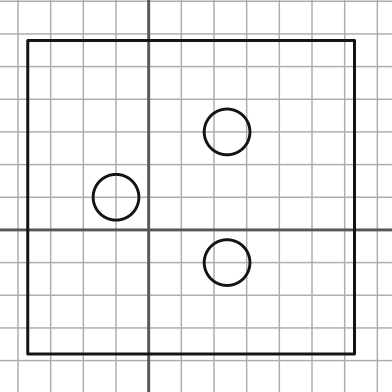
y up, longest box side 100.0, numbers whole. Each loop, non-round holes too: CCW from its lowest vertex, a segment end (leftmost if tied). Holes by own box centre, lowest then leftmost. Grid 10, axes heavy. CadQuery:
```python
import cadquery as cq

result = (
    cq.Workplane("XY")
    .moveTo(-37.0, -38.0)
    .lineTo(63.0, -38.0)
    .lineTo(63.0, 58.0)
    .lineTo(-37.0, 58.0)
    .close()
    .moveTo(24.0, -10.0)
    .circle(7.0)
    .moveTo(-10.0, 10.0)
    .circle(7.0)
    .moveTo(24.0, 30.0)
    .circle(7.0)
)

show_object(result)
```